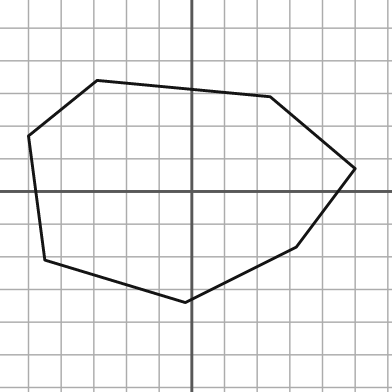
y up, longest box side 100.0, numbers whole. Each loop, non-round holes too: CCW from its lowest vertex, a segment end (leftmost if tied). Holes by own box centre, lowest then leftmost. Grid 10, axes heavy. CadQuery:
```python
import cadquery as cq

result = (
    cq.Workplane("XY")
    .moveTo(-2.0, -34.0)
    .lineTo(32.0, -17.0)
    .lineTo(50.0, 7.0)
    .lineTo(24.0, 29.0)
    .lineTo(-29.0, 34.0)
    .lineTo(-50.0, 17.0)
    .lineTo(-45.0, -21.0)
    .close()
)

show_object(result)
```